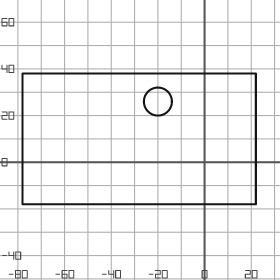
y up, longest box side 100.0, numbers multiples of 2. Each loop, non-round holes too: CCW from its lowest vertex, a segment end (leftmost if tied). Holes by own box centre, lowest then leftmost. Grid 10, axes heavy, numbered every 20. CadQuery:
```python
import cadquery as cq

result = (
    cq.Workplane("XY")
    .moveTo(-78.0, -18.0)
    .lineTo(22.0, -18.0)
    .lineTo(22.0, 38.0)
    .lineTo(-78.0, 38.0)
    .close()
    .moveTo(-20.0, 26.0)
    .circle(6.0)
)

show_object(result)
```